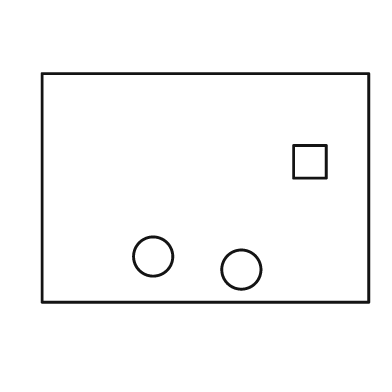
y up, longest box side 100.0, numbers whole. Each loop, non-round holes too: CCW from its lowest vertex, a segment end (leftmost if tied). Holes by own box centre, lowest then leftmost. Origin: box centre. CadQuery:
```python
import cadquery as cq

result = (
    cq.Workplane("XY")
    .moveTo(-50.0, -35.0)
    .lineTo(50.0, -35.0)
    .lineTo(50.0, 35.0)
    .lineTo(-50.0, 35.0)
    .close()
    .moveTo(11.0, -25.0)
    .circle(6.0)
    .moveTo(-16.0, -21.0)
    .circle(6.0)
    .moveTo(27.0, 3.0)
    .lineTo(37.0, 3.0)
    .lineTo(37.0, 13.0)
    .lineTo(27.0, 13.0)
    .close()
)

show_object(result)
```